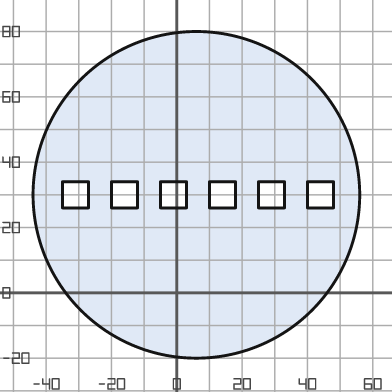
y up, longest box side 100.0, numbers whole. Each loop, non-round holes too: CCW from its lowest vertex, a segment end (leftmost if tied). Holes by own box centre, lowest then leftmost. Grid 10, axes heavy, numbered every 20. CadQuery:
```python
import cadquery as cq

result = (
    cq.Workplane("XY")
    .moveTo(6.0, 30.0)
    .circle(50.0)
    .moveTo(-35.0, 26.0)
    .lineTo(-27.0, 26.0)
    .lineTo(-27.0, 34.0)
    .lineTo(-35.0, 34.0)
    .close()
    .moveTo(-20.0, 26.0)
    .lineTo(-12.0, 26.0)
    .lineTo(-12.0, 34.0)
    .lineTo(-20.0, 34.0)
    .close()
    .moveTo(-5.0, 26.0)
    .lineTo(3.0, 26.0)
    .lineTo(3.0, 34.0)
    .lineTo(-5.0, 34.0)
    .close()
    .moveTo(10.0, 26.0)
    .lineTo(18.0, 26.0)
    .lineTo(18.0, 34.0)
    .lineTo(10.0, 34.0)
    .close()
    .moveTo(25.0, 26.0)
    .lineTo(33.0, 26.0)
    .lineTo(33.0, 34.0)
    .lineTo(25.0, 34.0)
    .close()
    .moveTo(40.0, 26.0)
    .lineTo(48.0, 26.0)
    .lineTo(48.0, 34.0)
    .lineTo(40.0, 34.0)
    .close()
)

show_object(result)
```